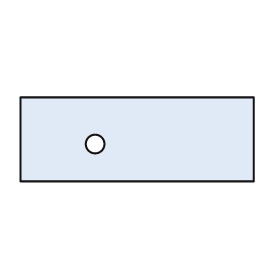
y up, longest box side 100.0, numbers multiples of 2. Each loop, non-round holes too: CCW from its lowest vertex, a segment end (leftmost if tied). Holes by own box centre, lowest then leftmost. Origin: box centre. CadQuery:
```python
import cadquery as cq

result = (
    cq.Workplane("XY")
    .moveTo(-50.0, -18.0)
    .lineTo(50.0, -18.0)
    .lineTo(50.0, 18.0)
    .lineTo(-50.0, 18.0)
    .close()
    .moveTo(-18.0, -2.0)
    .circle(4.0)
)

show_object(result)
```